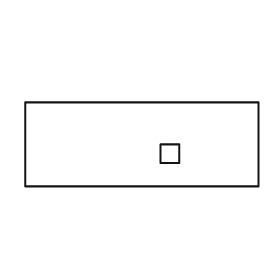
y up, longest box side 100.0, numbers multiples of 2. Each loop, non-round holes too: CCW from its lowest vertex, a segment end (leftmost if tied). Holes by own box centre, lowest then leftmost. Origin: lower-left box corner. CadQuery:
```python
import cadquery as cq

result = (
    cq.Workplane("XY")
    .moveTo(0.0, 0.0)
    .lineTo(100.0, 0.0)
    .lineTo(100.0, 36.0)
    .lineTo(0.0, 36.0)
    .close()
    .moveTo(58.0, 10.0)
    .lineTo(66.0, 10.0)
    .lineTo(66.0, 18.0)
    .lineTo(58.0, 18.0)
    .close()
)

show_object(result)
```